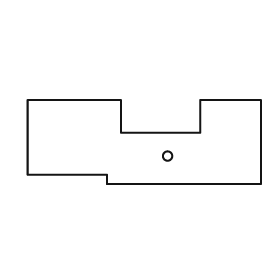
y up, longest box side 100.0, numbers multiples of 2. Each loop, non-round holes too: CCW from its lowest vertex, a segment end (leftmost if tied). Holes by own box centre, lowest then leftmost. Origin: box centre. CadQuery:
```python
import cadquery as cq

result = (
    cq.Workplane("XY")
    .moveTo(-16.0, -18.0)
    .lineTo(50.0, -18.0)
    .lineTo(50.0, 18.0)
    .lineTo(24.0, 18.0)
    .lineTo(24.0, 4.0)
    .lineTo(-10.0, 4.0)
    .lineTo(-10.0, 18.0)
    .lineTo(-50.0, 18.0)
    .lineTo(-50.0, -14.0)
    .lineTo(-16.0, -14.0)
    .close()
    .moveTo(10.0, -6.0)
    .circle(2.0)
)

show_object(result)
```